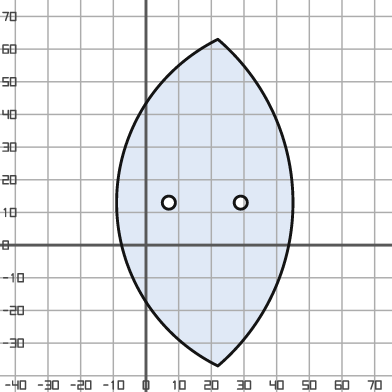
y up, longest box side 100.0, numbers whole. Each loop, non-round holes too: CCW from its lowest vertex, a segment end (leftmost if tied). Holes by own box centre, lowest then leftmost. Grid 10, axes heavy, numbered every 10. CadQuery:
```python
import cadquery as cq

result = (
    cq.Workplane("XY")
    .moveTo(22.0, -37.0)
    .threePointArc((45.0, 13.0), (22.0, 63.0))
    .threePointArc((-9.0, 13.0), (22.0, -37.0))
    .close()
    .moveTo(7.0, 13.0)
    .circle(2.0)
    .moveTo(29.0, 13.0)
    .circle(2.0)
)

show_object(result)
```